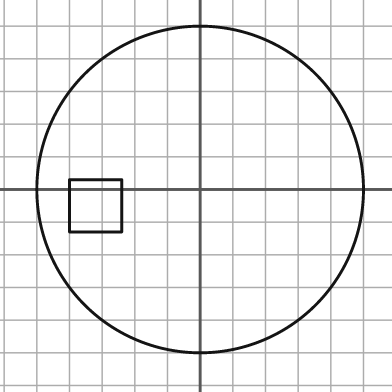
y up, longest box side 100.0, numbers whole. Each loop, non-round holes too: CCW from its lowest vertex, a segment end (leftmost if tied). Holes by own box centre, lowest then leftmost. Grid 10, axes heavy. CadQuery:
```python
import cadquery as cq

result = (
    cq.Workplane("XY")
    .moveTo(0.0, 0.0)
    .circle(50.0)
    .moveTo(-40.0, -13.0)
    .lineTo(-24.0, -13.0)
    .lineTo(-24.0, 3.0)
    .lineTo(-40.0, 3.0)
    .close()
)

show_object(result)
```